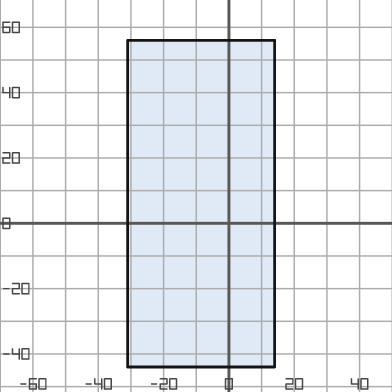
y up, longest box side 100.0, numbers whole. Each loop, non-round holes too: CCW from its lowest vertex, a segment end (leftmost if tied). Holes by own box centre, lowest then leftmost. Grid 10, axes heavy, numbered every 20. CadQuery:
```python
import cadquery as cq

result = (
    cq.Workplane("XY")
    .moveTo(-31.0, -44.0)
    .lineTo(14.0, -44.0)
    .lineTo(14.0, 56.0)
    .lineTo(-31.0, 56.0)
    .close()
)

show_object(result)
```